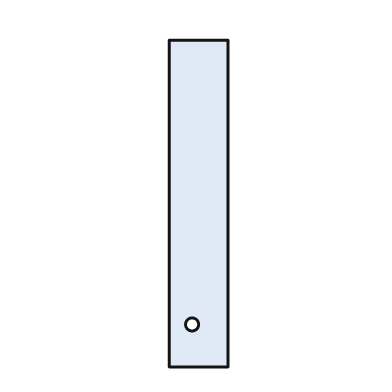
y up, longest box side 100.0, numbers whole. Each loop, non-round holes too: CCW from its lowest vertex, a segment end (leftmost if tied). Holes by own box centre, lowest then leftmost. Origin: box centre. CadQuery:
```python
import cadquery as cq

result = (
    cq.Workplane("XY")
    .moveTo(-9.0, -50.0)
    .lineTo(9.0, -50.0)
    .lineTo(9.0, 50.0)
    .lineTo(-9.0, 50.0)
    .close()
    .moveTo(-2.0, -37.0)
    .circle(2.0)
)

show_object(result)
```